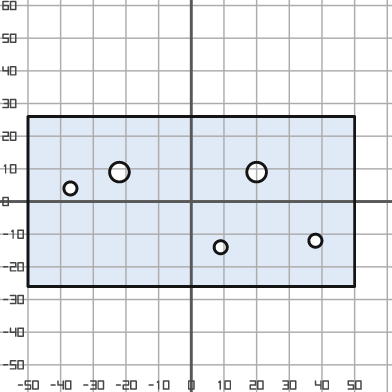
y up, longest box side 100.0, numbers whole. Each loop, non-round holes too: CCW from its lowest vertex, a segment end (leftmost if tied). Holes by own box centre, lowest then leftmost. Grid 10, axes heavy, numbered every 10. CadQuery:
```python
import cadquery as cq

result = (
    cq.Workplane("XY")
    .moveTo(-50.0, -26.0)
    .lineTo(50.0, -26.0)
    .lineTo(50.0, 26.0)
    .lineTo(-50.0, 26.0)
    .close()
    .moveTo(9.0, -14.0)
    .circle(2.0)
    .moveTo(38.0, -12.0)
    .circle(2.0)
    .moveTo(-37.0, 4.0)
    .circle(2.0)
    .moveTo(-22.0, 9.0)
    .circle(3.0)
    .moveTo(20.0, 9.0)
    .circle(3.0)
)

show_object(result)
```